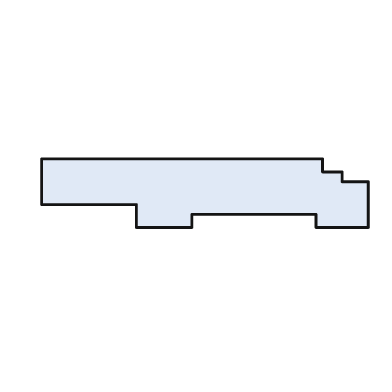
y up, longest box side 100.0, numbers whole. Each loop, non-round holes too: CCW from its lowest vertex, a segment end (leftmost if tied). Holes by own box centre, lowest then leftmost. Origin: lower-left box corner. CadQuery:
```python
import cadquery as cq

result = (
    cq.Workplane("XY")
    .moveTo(29.0, 0.0)
    .lineTo(46.0, 0.0)
    .lineTo(46.0, 4.0)
    .lineTo(84.0, 4.0)
    .lineTo(84.0, 0.0)
    .lineTo(100.0, 0.0)
    .lineTo(100.0, 14.0)
    .lineTo(92.0, 14.0)
    .lineTo(92.0, 17.0)
    .lineTo(86.0, 17.0)
    .lineTo(86.0, 21.0)
    .lineTo(0.0, 21.0)
    .lineTo(0.0, 7.0)
    .lineTo(29.0, 7.0)
    .close()
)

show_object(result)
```